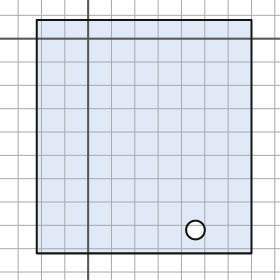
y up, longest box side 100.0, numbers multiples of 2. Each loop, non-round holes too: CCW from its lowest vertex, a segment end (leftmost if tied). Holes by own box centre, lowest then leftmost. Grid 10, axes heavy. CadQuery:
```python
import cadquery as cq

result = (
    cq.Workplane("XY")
    .moveTo(-22.0, -92.0)
    .lineTo(70.0, -92.0)
    .lineTo(70.0, 8.0)
    .lineTo(-22.0, 8.0)
    .close()
    .moveTo(46.0, -82.0)
    .circle(4.0)
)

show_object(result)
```